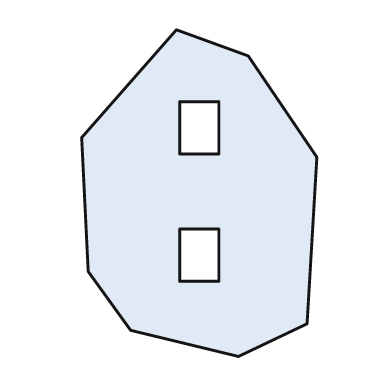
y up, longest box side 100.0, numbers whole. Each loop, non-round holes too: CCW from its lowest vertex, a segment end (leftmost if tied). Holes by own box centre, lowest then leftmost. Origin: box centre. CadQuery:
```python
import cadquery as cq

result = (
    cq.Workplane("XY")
    .moveTo(12.0, -50.0)
    .lineTo(33.0, -40.0)
    .lineTo(36.0, 11.0)
    .lineTo(15.0, 42.0)
    .lineTo(-7.0, 50.0)
    .lineTo(-36.0, 17.0)
    .lineTo(-34.0, -24.0)
    .lineTo(-21.0, -42.0)
    .close()
    .moveTo(-6.0, -27.0)
    .lineTo(6.0, -27.0)
    .lineTo(6.0, -11.0)
    .lineTo(-6.0, -11.0)
    .close()
    .moveTo(-6.0, 12.0)
    .lineTo(6.0, 12.0)
    .lineTo(6.0, 28.0)
    .lineTo(-6.0, 28.0)
    .close()
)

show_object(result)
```